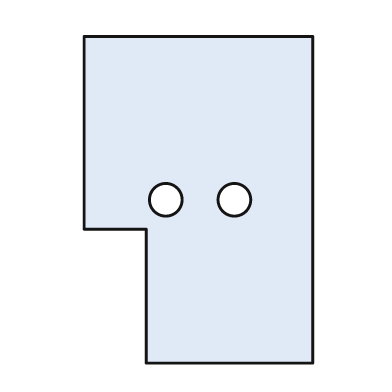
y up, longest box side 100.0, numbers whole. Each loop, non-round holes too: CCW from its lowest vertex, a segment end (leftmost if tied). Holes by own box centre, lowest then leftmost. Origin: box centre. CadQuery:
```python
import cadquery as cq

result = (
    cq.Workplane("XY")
    .moveTo(-16.0, -50.0)
    .lineTo(35.0, -50.0)
    .lineTo(35.0, 50.0)
    .lineTo(-35.0, 50.0)
    .lineTo(-35.0, -9.0)
    .lineTo(-16.0, -9.0)
    .close()
    .moveTo(-10.0, 0.0)
    .circle(5.0)
    .moveTo(11.0, 0.0)
    .circle(5.0)
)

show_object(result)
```